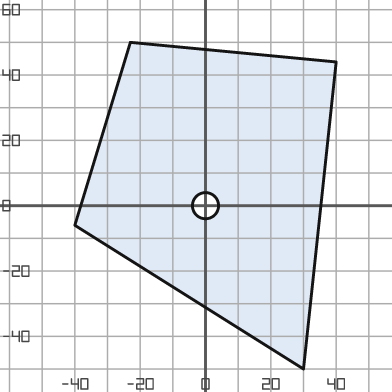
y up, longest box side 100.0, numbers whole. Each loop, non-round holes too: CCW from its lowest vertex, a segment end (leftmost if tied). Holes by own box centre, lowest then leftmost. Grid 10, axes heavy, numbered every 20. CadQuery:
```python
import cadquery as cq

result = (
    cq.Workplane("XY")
    .moveTo(30.0, -50.0)
    .lineTo(40.0, 44.0)
    .lineTo(-23.0, 50.0)
    .lineTo(-40.0, -6.0)
    .close()
    .moveTo(0.0, 0.0)
    .circle(4.0)
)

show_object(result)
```